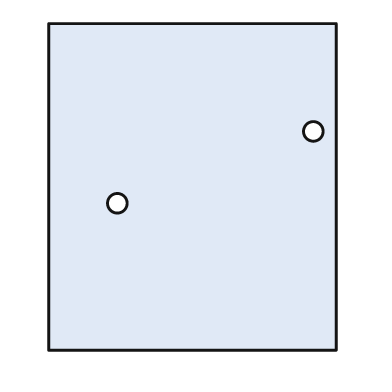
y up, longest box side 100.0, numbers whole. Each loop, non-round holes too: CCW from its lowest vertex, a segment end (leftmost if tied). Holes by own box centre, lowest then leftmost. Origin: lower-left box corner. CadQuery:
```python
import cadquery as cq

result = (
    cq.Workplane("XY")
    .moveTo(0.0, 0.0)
    .lineTo(88.0, 0.0)
    .lineTo(88.0, 100.0)
    .lineTo(0.0, 100.0)
    .close()
    .moveTo(21.0, 45.0)
    .circle(3.0)
    .moveTo(81.0, 67.0)
    .circle(3.0)
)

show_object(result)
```